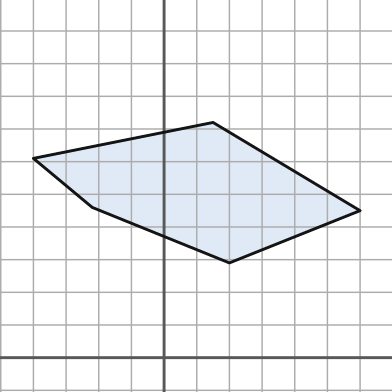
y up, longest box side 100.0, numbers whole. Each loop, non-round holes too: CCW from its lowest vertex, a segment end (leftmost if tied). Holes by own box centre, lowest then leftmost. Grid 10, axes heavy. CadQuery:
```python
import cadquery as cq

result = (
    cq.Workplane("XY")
    .moveTo(20.0, 29.0)
    .lineTo(60.0, 45.0)
    .lineTo(15.0, 72.0)
    .lineTo(-40.0, 61.0)
    .lineTo(-22.0, 46.0)
    .close()
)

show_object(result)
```